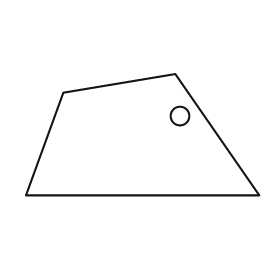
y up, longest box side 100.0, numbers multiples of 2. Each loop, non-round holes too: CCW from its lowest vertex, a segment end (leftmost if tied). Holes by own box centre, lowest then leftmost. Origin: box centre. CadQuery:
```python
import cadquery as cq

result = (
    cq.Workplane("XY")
    .moveTo(-50.0, -26.0)
    .lineTo(50.0, -26.0)
    .lineTo(14.0, 26.0)
    .lineTo(-34.0, 18.0)
    .close()
    .moveTo(16.0, 8.0)
    .circle(4.0)
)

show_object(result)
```